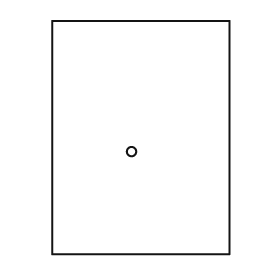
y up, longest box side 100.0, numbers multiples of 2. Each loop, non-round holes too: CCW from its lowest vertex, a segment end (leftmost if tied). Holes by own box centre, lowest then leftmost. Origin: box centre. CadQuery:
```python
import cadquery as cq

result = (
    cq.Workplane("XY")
    .moveTo(-38.0, -50.0)
    .lineTo(38.0, -50.0)
    .lineTo(38.0, 50.0)
    .lineTo(-38.0, 50.0)
    .close()
    .moveTo(-4.0, -6.0)
    .circle(2.0)
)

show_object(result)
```